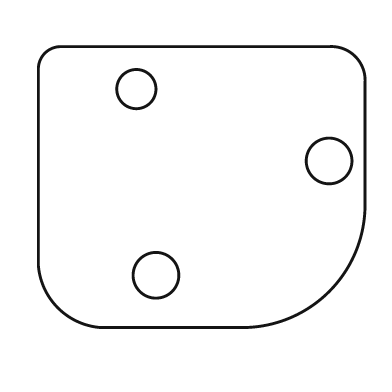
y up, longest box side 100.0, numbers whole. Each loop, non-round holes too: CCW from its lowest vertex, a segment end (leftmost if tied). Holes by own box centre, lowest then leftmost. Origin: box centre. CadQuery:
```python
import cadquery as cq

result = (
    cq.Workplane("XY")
    .moveTo(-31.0, -43.0)
    .lineTo(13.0, -43.0)
    .threePointArc((39.0, -32.0), (50.0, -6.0))
    .lineTo(50.0, 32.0)
    .threePointArc((47.0, 40.0), (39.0, 43.0))
    .lineTo(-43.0, 43.0)
    .threePointArc((-48.0, 41.0), (-50.0, 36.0))
    .lineTo(-50.0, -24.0)
    .threePointArc((-44.0, -37.0), (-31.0, -43.0))
    .close()
    .moveTo(-14.0, -27.0)
    .circle(7.0)
    .moveTo(39.0, 8.0)
    .circle(7.0)
    .moveTo(-20.0, 30.0)
    .circle(6.0)
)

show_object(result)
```